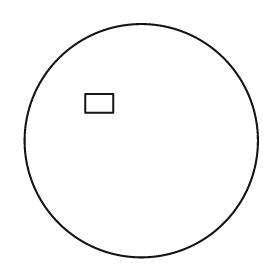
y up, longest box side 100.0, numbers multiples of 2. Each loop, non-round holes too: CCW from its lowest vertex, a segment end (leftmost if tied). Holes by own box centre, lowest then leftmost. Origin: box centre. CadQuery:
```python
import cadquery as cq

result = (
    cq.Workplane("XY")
    .moveTo(0.0, 0.0)
    .circle(50.0)
    .moveTo(-24.0, 12.0)
    .lineTo(-12.0, 12.0)
    .lineTo(-12.0, 20.0)
    .lineTo(-24.0, 20.0)
    .close()
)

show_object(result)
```